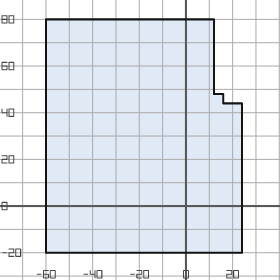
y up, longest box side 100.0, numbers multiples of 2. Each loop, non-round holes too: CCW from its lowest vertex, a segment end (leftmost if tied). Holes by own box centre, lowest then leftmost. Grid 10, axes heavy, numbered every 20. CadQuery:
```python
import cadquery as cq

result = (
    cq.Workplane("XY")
    .moveTo(-60.0, -20.0)
    .lineTo(24.0, -20.0)
    .lineTo(24.0, 44.0)
    .lineTo(16.0, 44.0)
    .lineTo(16.0, 48.0)
    .lineTo(12.0, 48.0)
    .lineTo(12.0, 80.0)
    .lineTo(-60.0, 80.0)
    .close()
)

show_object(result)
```